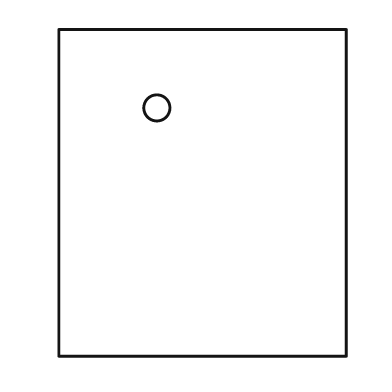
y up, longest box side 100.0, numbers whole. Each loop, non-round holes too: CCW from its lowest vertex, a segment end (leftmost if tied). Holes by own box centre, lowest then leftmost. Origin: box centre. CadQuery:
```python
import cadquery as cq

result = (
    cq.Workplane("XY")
    .moveTo(-44.0, -50.0)
    .lineTo(44.0, -50.0)
    .lineTo(44.0, 50.0)
    .lineTo(-44.0, 50.0)
    .close()
    .moveTo(-14.0, 26.0)
    .circle(4.0)
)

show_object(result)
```